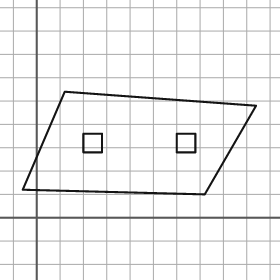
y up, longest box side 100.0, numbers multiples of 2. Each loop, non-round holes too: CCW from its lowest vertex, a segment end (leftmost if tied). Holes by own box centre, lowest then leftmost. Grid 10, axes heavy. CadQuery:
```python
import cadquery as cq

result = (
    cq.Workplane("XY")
    .moveTo(72.0, 10.0)
    .lineTo(94.0, 48.0)
    .lineTo(12.0, 54.0)
    .lineTo(-6.0, 12.0)
    .close()
    .moveTo(20.0, 28.0)
    .lineTo(28.0, 28.0)
    .lineTo(28.0, 36.0)
    .lineTo(20.0, 36.0)
    .close()
    .moveTo(60.0, 28.0)
    .lineTo(68.0, 28.0)
    .lineTo(68.0, 36.0)
    .lineTo(60.0, 36.0)
    .close()
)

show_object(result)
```